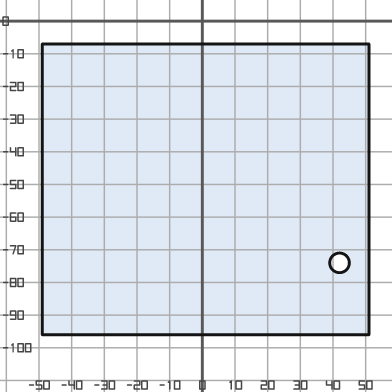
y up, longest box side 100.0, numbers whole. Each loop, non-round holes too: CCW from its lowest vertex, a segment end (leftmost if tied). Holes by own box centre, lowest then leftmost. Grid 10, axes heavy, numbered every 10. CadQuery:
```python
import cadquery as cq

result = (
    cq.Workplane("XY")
    .moveTo(-49.0, -96.0)
    .lineTo(51.0, -96.0)
    .lineTo(51.0, -7.0)
    .lineTo(-49.0, -7.0)
    .close()
    .moveTo(42.0, -74.0)
    .circle(3.0)
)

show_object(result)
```